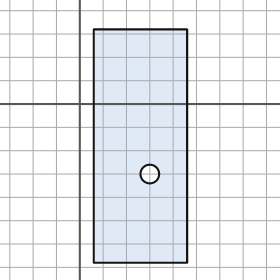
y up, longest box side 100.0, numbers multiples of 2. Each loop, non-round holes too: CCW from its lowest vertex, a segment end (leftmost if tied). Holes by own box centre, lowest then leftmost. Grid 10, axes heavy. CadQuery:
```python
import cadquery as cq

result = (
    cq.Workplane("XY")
    .moveTo(6.0, -68.0)
    .lineTo(46.0, -68.0)
    .lineTo(46.0, 32.0)
    .lineTo(6.0, 32.0)
    .close()
    .moveTo(30.0, -30.0)
    .circle(4.0)
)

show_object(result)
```